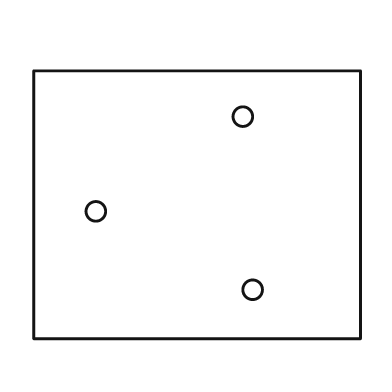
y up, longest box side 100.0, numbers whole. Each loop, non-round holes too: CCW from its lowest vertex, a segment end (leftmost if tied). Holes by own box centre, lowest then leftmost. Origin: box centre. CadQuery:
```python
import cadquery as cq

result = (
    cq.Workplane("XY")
    .moveTo(-50.0, -41.0)
    .lineTo(50.0, -41.0)
    .lineTo(50.0, 41.0)
    .lineTo(-50.0, 41.0)
    .close()
    .moveTo(17.0, -26.0)
    .circle(3.0)
    .moveTo(-31.0, -2.0)
    .circle(3.0)
    .moveTo(14.0, 27.0)
    .circle(3.0)
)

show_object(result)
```